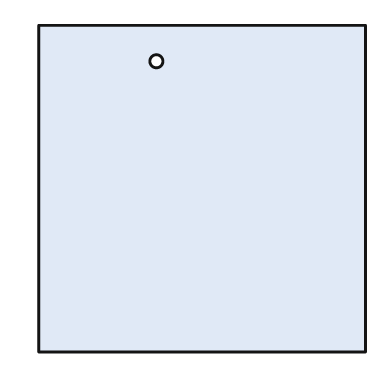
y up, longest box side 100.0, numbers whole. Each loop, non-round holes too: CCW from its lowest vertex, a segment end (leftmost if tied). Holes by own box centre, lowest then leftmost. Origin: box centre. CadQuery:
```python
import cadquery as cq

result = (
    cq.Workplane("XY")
    .moveTo(-50.0, -50.0)
    .lineTo(50.0, -50.0)
    .lineTo(50.0, 50.0)
    .lineTo(-50.0, 50.0)
    .close()
    .moveTo(-14.0, 39.0)
    .circle(2.0)
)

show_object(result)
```